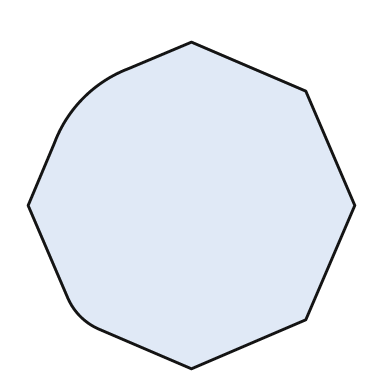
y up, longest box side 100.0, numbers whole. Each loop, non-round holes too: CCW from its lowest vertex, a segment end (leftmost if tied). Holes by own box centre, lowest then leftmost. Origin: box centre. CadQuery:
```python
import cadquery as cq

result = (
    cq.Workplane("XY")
    .moveTo(0.0, -50.0)
    .lineTo(35.0, -35.0)
    .lineTo(50.0, 0.0)
    .lineTo(35.0, 35.0)
    .lineTo(0.0, 50.0)
    .lineTo(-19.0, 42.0)
    .threePointArc((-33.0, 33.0), (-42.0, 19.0))
    .lineTo(-50.0, 0.0)
    .lineTo(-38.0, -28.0)
    .threePointArc((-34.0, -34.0), (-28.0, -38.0))
    .close()
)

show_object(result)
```